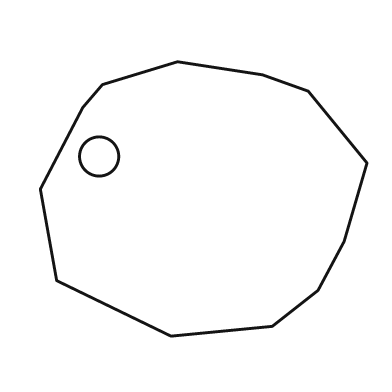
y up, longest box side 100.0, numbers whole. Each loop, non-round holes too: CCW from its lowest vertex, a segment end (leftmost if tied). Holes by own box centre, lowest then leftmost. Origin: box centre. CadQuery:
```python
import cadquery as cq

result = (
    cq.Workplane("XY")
    .moveTo(-10.0, -42.0)
    .lineTo(21.0, -39.0)
    .lineTo(35.0, -28.0)
    .lineTo(43.0, -13.0)
    .lineTo(50.0, 11.0)
    .lineTo(32.0, 33.0)
    .lineTo(18.0, 38.0)
    .lineTo(-8.0, 42.0)
    .lineTo(-31.0, 35.0)
    .lineTo(-37.0, 28.0)
    .lineTo(-50.0, 3.0)
    .lineTo(-45.0, -25.0)
    .close()
    .moveTo(-32.0, 13.0)
    .circle(6.0)
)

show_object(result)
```